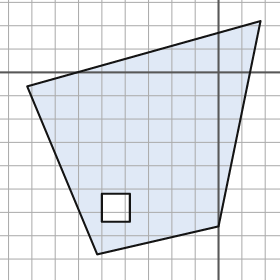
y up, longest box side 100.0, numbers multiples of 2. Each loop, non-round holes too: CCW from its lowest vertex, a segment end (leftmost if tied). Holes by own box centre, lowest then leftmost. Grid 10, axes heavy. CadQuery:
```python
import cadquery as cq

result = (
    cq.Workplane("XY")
    .moveTo(-52.0, -78.0)
    .lineTo(0.0, -66.0)
    .lineTo(18.0, 22.0)
    .lineTo(-82.0, -6.0)
    .close()
    .moveTo(-50.0, -64.0)
    .lineTo(-38.0, -64.0)
    .lineTo(-38.0, -52.0)
    .lineTo(-50.0, -52.0)
    .close()
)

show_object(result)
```